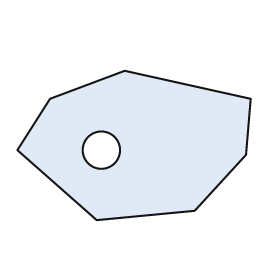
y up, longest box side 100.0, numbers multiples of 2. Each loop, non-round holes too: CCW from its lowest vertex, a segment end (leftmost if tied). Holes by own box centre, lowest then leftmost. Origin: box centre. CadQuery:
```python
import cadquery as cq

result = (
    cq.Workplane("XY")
    .moveTo(-16.0, -32.0)
    .lineTo(26.0, -28.0)
    .lineTo(48.0, -4.0)
    .lineTo(50.0, 20.0)
    .lineTo(-4.0, 32.0)
    .lineTo(-36.0, 20.0)
    .lineTo(-50.0, -2.0)
    .close()
    .moveTo(-14.0, -2.0)
    .circle(8.0)
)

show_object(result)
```